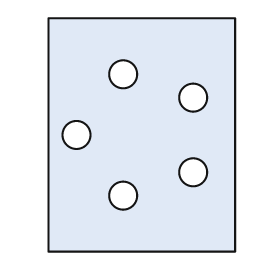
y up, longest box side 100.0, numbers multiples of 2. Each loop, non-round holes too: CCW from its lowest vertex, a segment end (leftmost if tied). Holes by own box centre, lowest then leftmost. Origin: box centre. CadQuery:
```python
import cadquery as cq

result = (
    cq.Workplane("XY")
    .moveTo(-40.0, -50.0)
    .lineTo(40.0, -50.0)
    .lineTo(40.0, 50.0)
    .lineTo(-40.0, 50.0)
    .close()
    .moveTo(-8.0, -26.0)
    .circle(6.0)
    .moveTo(22.0, -16.0)
    .circle(6.0)
    .moveTo(-28.0, 0.0)
    .circle(6.0)
    .moveTo(22.0, 16.0)
    .circle(6.0)
    .moveTo(-8.0, 26.0)
    .circle(6.0)
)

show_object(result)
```